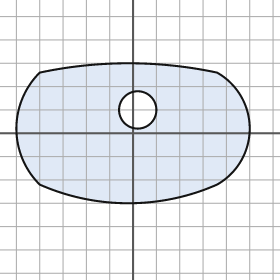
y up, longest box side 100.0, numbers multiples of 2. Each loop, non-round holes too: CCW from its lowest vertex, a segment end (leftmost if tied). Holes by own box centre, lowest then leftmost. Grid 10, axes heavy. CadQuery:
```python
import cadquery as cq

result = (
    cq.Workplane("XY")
    .moveTo(-40.0, -22.0)
    .threePointArc((-2.0, -30.0), (36.0, -22.0))
    .threePointArc((50.0, 2.0), (36.0, 26.0))
    .threePointArc((-2.0, 30.0), (-40.0, 26.0))
    .threePointArc((-50.0, 2.0), (-40.0, -22.0))
    .close()
    .moveTo(2.0, 10.0)
    .circle(8.0)
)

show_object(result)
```